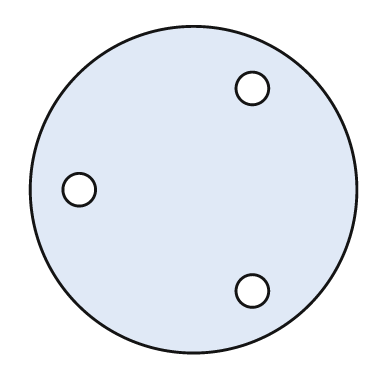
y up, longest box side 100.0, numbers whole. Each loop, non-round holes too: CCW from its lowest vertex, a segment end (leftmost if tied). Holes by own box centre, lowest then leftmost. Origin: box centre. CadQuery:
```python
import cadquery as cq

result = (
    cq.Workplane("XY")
    .moveTo(0.0, 0.0)
    .circle(50.0)
    .moveTo(18.0, -31.0)
    .circle(5.0)
    .moveTo(-35.0, 0.0)
    .circle(5.0)
    .moveTo(18.0, 31.0)
    .circle(5.0)
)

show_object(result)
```